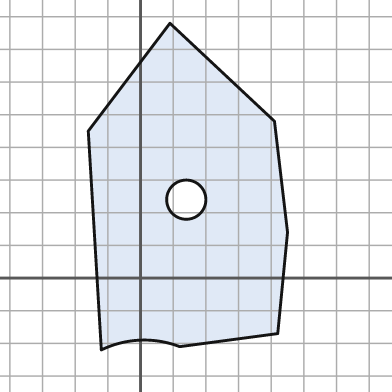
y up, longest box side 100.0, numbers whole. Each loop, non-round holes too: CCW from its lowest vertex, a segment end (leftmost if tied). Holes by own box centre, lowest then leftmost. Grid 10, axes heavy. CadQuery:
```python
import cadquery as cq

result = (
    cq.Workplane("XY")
    .moveTo(-12.0, -22.0)
    .threePointArc((0.0, -19.0), (12.0, -21.0))
    .lineTo(42.0, -17.0)
    .lineTo(45.0, 14.0)
    .lineTo(41.0, 48.0)
    .lineTo(9.0, 78.0)
    .lineTo(-16.0, 45.0)
    .close()
    .moveTo(14.0, 24.0)
    .circle(6.0)
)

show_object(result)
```